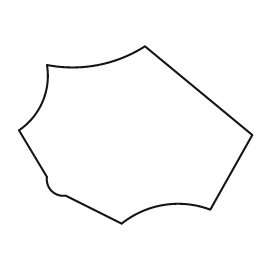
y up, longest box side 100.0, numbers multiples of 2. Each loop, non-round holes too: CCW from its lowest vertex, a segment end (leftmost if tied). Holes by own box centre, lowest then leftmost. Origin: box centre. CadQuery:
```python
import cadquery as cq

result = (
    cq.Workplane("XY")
    .moveTo(-6.0, -38.0)
    .threePointArc((12.0, -30.0), (32.0, -32.0))
    .lineTo(50.0, 0.0)
    .lineTo(4.0, 38.0)
    .threePointArc((-16.0, 30.0), (-38.0, 30.0))
    .threePointArc((-40.0, 14.0), (-50.0, 2.0))
    .lineTo(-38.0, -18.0)
    .threePointArc((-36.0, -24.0), (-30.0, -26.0))
    .close()
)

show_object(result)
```